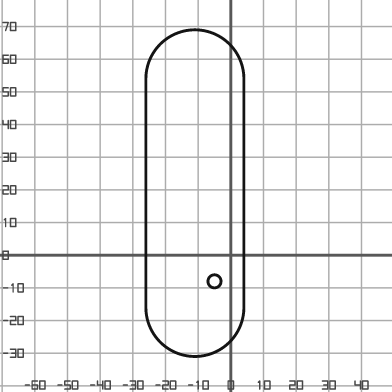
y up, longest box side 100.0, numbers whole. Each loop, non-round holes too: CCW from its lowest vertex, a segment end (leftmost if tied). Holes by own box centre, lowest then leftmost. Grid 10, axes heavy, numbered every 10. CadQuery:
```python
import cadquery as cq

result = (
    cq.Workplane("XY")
    .moveTo(-26.0, -16.0)
    .threePointArc((-11.0, -31.0), (4.0, -16.0))
    .lineTo(4.0, 54.0)
    .threePointArc((-11.0, 69.0), (-26.0, 54.0))
    .close()
    .moveTo(-5.0, -8.0)
    .circle(2.0)
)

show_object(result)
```